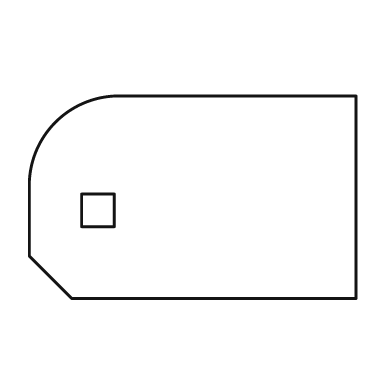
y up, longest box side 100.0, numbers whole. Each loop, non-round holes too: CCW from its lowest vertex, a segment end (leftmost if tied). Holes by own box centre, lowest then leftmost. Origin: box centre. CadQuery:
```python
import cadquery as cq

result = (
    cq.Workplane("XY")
    .moveTo(-37.0, -31.0)
    .lineTo(50.0, -31.0)
    .lineTo(50.0, 31.0)
    .lineTo(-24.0, 31.0)
    .threePointArc((-42.0, 23.0), (-50.0, 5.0))
    .lineTo(-50.0, -18.0)
    .close()
    .moveTo(-34.0, -9.0)
    .lineTo(-24.0, -9.0)
    .lineTo(-24.0, 1.0)
    .lineTo(-34.0, 1.0)
    .close()
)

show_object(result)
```